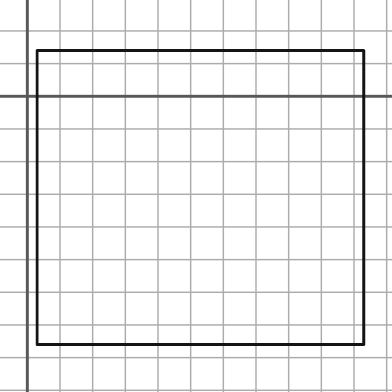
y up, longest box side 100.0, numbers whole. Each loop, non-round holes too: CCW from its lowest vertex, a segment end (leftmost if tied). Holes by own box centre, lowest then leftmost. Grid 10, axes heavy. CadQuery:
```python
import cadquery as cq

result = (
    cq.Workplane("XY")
    .moveTo(3.0, -76.0)
    .lineTo(103.0, -76.0)
    .lineTo(103.0, 14.0)
    .lineTo(3.0, 14.0)
    .close()
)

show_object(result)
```